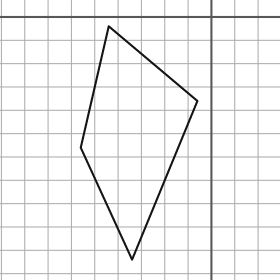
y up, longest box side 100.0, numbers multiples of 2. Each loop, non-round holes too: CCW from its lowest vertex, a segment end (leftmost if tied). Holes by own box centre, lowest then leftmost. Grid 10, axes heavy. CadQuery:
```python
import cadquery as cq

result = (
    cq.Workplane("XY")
    .moveTo(-34.0, -104.0)
    .lineTo(-6.0, -36.0)
    .lineTo(-44.0, -4.0)
    .lineTo(-56.0, -56.0)
    .close()
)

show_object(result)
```